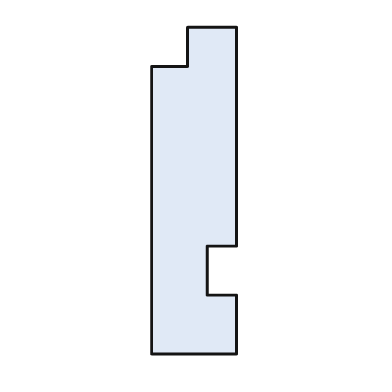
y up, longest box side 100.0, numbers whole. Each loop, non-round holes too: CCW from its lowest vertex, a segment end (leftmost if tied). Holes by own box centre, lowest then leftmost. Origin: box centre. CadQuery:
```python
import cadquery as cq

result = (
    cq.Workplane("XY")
    .moveTo(-13.0, -50.0)
    .lineTo(13.0, -50.0)
    .lineTo(13.0, -32.0)
    .lineTo(4.0, -32.0)
    .lineTo(4.0, -17.0)
    .lineTo(13.0, -17.0)
    .lineTo(13.0, 50.0)
    .lineTo(-2.0, 50.0)
    .lineTo(-2.0, 38.0)
    .lineTo(-13.0, 38.0)
    .close()
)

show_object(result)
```